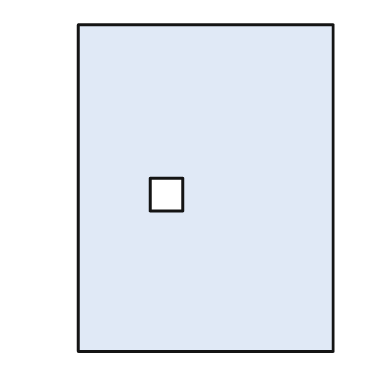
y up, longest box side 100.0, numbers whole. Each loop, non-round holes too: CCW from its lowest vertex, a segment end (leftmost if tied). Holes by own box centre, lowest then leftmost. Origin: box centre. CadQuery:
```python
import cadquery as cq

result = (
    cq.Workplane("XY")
    .moveTo(-39.0, -50.0)
    .lineTo(39.0, -50.0)
    .lineTo(39.0, 50.0)
    .lineTo(-39.0, 50.0)
    .close()
    .moveTo(-17.0, -7.0)
    .lineTo(-7.0, -7.0)
    .lineTo(-7.0, 3.0)
    .lineTo(-17.0, 3.0)
    .close()
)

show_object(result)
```